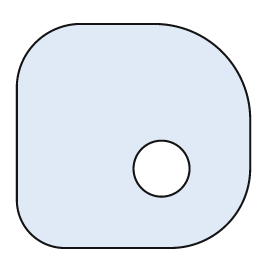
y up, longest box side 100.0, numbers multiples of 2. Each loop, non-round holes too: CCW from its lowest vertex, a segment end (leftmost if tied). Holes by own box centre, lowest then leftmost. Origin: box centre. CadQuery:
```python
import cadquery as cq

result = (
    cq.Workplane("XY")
    .moveTo(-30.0, -48.0)
    .lineTo(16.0, -48.0)
    .threePointArc((40.0, -38.0), (50.0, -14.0))
    .lineTo(50.0, 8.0)
    .threePointArc((38.0, 36.0), (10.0, 48.0))
    .lineTo(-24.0, 48.0)
    .threePointArc((-42.0, 40.0), (-50.0, 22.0))
    .lineTo(-50.0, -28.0)
    .threePointArc((-44.0, -42.0), (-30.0, -48.0))
    .close()
    .moveTo(12.0, -14.0)
    .circle(12.0)
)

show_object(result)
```